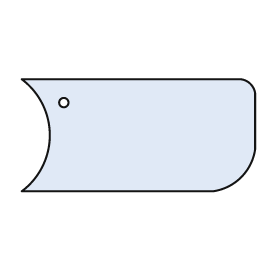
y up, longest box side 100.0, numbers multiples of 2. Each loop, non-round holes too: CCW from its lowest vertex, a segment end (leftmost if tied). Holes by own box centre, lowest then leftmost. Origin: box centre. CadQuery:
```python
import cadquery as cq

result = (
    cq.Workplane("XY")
    .moveTo(-50.0, -24.0)
    .lineTo(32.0, -24.0)
    .threePointArc((44.0, -18.0), (50.0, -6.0))
    .lineTo(50.0, 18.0)
    .threePointArc((48.0, 22.0), (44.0, 24.0))
    .lineTo(-50.0, 24.0)
    .threePointArc((-38.0, 0.0), (-50.0, -24.0))
    .close()
    .moveTo(-32.0, 14.0)
    .circle(2.0)
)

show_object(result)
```